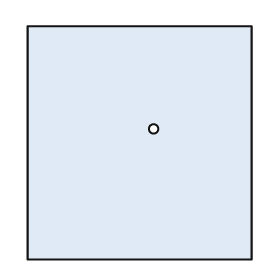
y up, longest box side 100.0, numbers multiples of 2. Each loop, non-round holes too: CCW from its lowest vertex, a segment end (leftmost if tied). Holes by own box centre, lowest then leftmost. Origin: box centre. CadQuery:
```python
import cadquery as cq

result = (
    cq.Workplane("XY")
    .moveTo(-48.0, -50.0)
    .lineTo(48.0, -50.0)
    .lineTo(48.0, 50.0)
    .lineTo(-48.0, 50.0)
    .close()
    .moveTo(6.0, 6.0)
    .circle(2.0)
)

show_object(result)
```